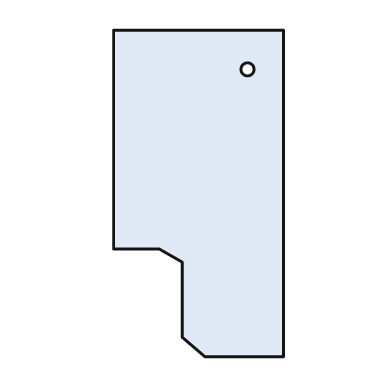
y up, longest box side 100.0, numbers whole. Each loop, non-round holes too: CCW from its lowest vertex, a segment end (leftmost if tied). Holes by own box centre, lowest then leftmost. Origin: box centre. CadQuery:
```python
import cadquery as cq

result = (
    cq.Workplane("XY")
    .moveTo(2.0, -50.0)
    .lineTo(26.0, -50.0)
    .lineTo(26.0, 50.0)
    .lineTo(-26.0, 50.0)
    .lineTo(-26.0, -17.0)
    .lineTo(-12.0, -17.0)
    .lineTo(-5.0, -21.0)
    .lineTo(-5.0, -44.0)
    .close()
    .moveTo(15.0, 38.0)
    .circle(2.0)
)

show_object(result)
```